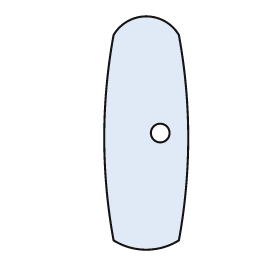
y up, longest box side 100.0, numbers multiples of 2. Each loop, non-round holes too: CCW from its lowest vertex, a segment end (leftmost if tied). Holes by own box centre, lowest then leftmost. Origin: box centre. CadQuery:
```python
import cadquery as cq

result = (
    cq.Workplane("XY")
    .moveTo(-14.0, -46.0)
    .threePointArc((0.0, -50.0), (14.0, -46.0))
    .threePointArc((18.0, -2.0), (14.0, 42.0))
    .threePointArc((0.0, 50.0), (-14.0, 42.0))
    .threePointArc((-18.0, -2.0), (-14.0, -46.0))
    .close()
    .moveTo(6.0, 0.0)
    .circle(4.0)
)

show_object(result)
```